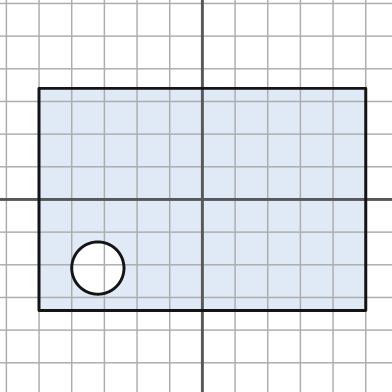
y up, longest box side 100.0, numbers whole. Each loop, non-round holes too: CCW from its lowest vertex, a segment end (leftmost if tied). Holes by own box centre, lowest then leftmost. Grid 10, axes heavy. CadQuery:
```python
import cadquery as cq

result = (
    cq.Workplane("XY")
    .moveTo(-50.0, -34.0)
    .lineTo(50.0, -34.0)
    .lineTo(50.0, 34.0)
    .lineTo(-50.0, 34.0)
    .close()
    .moveTo(-32.0, -21.0)
    .circle(8.0)
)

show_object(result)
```